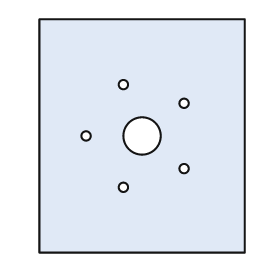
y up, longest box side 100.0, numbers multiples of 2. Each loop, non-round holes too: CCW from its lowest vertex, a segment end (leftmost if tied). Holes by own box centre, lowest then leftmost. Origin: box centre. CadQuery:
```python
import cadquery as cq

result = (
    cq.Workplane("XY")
    .moveTo(-44.0, -50.0)
    .lineTo(44.0, -50.0)
    .lineTo(44.0, 50.0)
    .lineTo(-44.0, 50.0)
    .close()
    .moveTo(-8.0, -22.0)
    .circle(2.0)
    .moveTo(18.0, -14.0)
    .circle(2.0)
    .moveTo(-24.0, 0.0)
    .circle(2.0)
    .moveTo(0.0, 0.0)
    .circle(8.0)
    .moveTo(18.0, 14.0)
    .circle(2.0)
    .moveTo(-8.0, 22.0)
    .circle(2.0)
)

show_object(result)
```